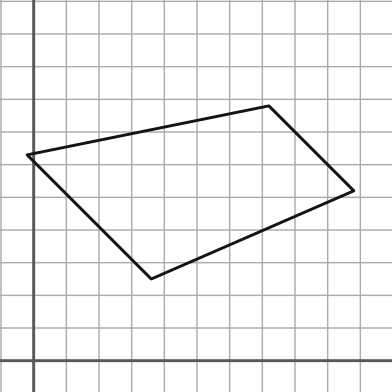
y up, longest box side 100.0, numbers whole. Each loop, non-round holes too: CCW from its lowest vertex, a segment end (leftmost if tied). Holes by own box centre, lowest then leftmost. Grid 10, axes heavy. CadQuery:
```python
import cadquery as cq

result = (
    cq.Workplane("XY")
    .moveTo(36.0, 25.0)
    .lineTo(98.0, 52.0)
    .lineTo(72.0, 78.0)
    .lineTo(-2.0, 63.0)
    .close()
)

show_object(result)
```